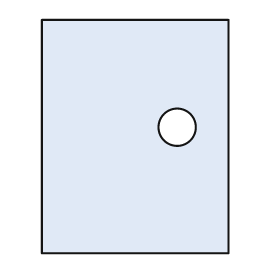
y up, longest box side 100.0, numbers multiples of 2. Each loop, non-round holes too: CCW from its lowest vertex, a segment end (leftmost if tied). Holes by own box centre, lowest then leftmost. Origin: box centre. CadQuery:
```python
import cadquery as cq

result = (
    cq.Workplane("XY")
    .moveTo(-40.0, -50.0)
    .lineTo(40.0, -50.0)
    .lineTo(40.0, 50.0)
    .lineTo(-40.0, 50.0)
    .close()
    .moveTo(18.0, 4.0)
    .circle(8.0)
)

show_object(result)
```